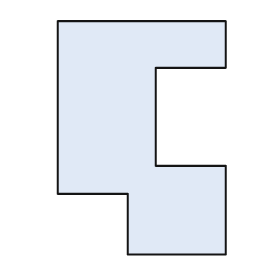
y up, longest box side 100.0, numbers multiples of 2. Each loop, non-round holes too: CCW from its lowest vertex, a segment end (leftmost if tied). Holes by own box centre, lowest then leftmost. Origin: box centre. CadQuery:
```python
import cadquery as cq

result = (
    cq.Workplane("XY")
    .moveTo(-6.0, -50.0)
    .lineTo(36.0, -50.0)
    .lineTo(36.0, -12.0)
    .lineTo(6.0, -12.0)
    .lineTo(6.0, 30.0)
    .lineTo(36.0, 30.0)
    .lineTo(36.0, 50.0)
    .lineTo(-36.0, 50.0)
    .lineTo(-36.0, -24.0)
    .lineTo(-6.0, -24.0)
    .close()
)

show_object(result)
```